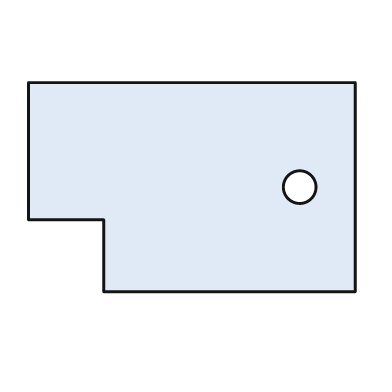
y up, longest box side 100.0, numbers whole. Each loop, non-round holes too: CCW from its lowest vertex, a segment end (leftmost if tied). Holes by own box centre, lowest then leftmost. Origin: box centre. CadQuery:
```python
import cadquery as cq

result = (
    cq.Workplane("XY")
    .moveTo(-27.0, -32.0)
    .lineTo(50.0, -32.0)
    .lineTo(50.0, 32.0)
    .lineTo(-50.0, 32.0)
    .lineTo(-50.0, -10.0)
    .lineTo(-27.0, -10.0)
    .close()
    .moveTo(33.0, 0.0)
    .circle(5.0)
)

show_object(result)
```